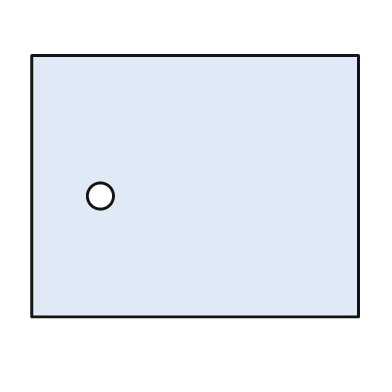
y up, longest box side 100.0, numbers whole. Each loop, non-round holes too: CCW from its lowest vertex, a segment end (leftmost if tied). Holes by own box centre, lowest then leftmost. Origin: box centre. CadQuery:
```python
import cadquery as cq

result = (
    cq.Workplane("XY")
    .moveTo(-50.0, -40.0)
    .lineTo(50.0, -40.0)
    .lineTo(50.0, 40.0)
    .lineTo(-50.0, 40.0)
    .close()
    .moveTo(-29.0, -3.0)
    .circle(4.0)
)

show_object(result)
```